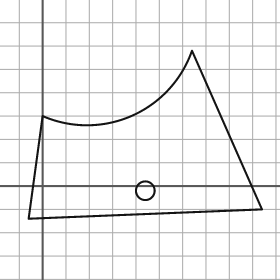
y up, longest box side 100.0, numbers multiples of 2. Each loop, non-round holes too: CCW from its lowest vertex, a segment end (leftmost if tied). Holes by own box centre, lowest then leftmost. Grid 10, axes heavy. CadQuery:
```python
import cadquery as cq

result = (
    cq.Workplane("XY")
    .moveTo(-6.0, -14.0)
    .lineTo(94.0, -10.0)
    .lineTo(64.0, 58.0)
    .threePointArc((38.0, 30.0), (0.0, 30.0))
    .close()
    .moveTo(44.0, -2.0)
    .circle(4.0)
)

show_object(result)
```